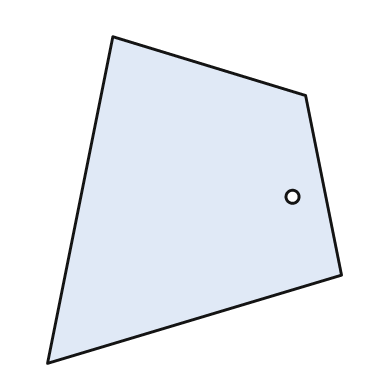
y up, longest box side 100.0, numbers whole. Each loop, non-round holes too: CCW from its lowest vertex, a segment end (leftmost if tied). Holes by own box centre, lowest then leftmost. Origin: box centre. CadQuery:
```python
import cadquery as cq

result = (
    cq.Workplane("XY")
    .moveTo(-45.0, -50.0)
    .lineTo(45.0, -23.0)
    .lineTo(34.0, 32.0)
    .lineTo(-25.0, 50.0)
    .close()
    .moveTo(30.0, 1.0)
    .circle(2.0)
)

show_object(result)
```